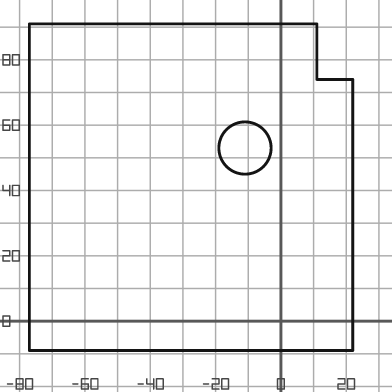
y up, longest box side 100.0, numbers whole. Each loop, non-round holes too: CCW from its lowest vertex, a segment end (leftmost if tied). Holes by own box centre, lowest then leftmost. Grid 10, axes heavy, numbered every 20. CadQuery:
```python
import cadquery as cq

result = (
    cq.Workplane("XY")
    .moveTo(-77.0, -9.0)
    .lineTo(22.0, -9.0)
    .lineTo(22.0, 74.0)
    .lineTo(11.0, 74.0)
    .lineTo(11.0, 91.0)
    .lineTo(-77.0, 91.0)
    .close()
    .moveTo(-11.0, 53.0)
    .circle(8.0)
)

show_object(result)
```